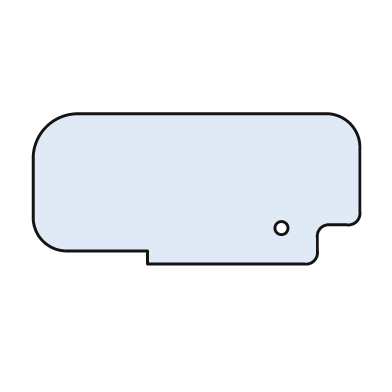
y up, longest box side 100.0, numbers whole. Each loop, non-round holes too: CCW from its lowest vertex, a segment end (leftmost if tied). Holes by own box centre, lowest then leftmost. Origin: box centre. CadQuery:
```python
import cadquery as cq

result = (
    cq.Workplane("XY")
    .moveTo(-15.0, -23.0)
    .lineTo(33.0, -23.0)
    .threePointArc((36.0, -22.0), (37.0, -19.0))
    .lineTo(37.0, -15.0)
    .threePointArc((38.0, -12.0), (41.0, -11.0))
    .lineTo(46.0, -11.0)
    .threePointArc((49.0, -10.0), (50.0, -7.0))
    .lineTo(50.0, 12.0)
    .threePointArc((47.0, 20.0), (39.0, 23.0))
    .lineTo(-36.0, 23.0)
    .threePointArc((-46.0, 19.0), (-50.0, 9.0))
    .lineTo(-50.0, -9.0)
    .threePointArc((-47.0, -16.0), (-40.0, -19.0))
    .lineTo(-15.0, -19.0)
    .close()
    .moveTo(26.0, -12.0)
    .circle(2.0)
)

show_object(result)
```